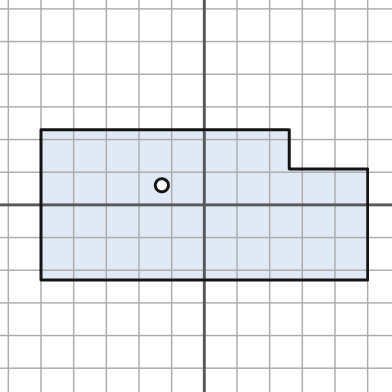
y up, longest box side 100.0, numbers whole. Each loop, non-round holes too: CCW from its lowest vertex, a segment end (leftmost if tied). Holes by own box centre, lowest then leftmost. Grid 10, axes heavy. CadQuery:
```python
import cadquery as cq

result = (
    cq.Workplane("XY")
    .moveTo(-50.0, -23.0)
    .lineTo(50.0, -23.0)
    .lineTo(50.0, 11.0)
    .lineTo(26.0, 11.0)
    .lineTo(26.0, 23.0)
    .lineTo(-50.0, 23.0)
    .close()
    .moveTo(-13.0, 6.0)
    .circle(2.0)
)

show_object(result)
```